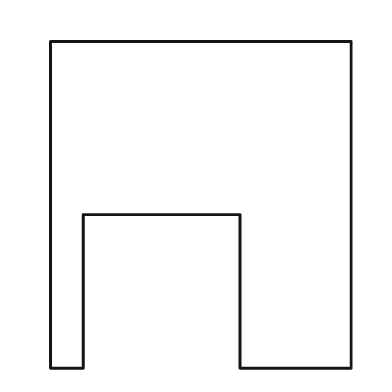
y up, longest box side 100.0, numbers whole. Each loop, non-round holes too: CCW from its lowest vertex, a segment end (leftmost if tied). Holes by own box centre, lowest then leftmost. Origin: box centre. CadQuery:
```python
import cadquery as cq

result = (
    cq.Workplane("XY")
    .moveTo(-46.0, -50.0)
    .lineTo(-36.0, -50.0)
    .lineTo(-36.0, -3.0)
    .lineTo(12.0, -3.0)
    .lineTo(12.0, -50.0)
    .lineTo(46.0, -50.0)
    .lineTo(46.0, 50.0)
    .lineTo(-46.0, 50.0)
    .close()
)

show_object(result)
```